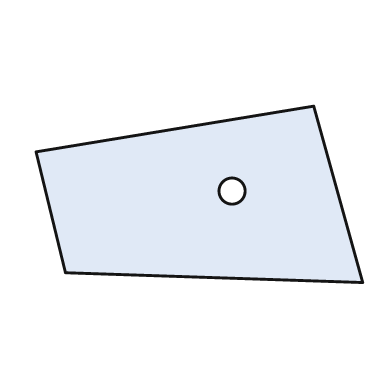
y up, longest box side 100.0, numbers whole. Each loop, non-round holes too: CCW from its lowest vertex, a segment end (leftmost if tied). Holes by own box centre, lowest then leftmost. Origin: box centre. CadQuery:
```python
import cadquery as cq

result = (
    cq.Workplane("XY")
    .moveTo(50.0, -27.0)
    .lineTo(35.0, 27.0)
    .lineTo(-50.0, 13.0)
    .lineTo(-41.0, -24.0)
    .close()
    .moveTo(10.0, 1.0)
    .circle(4.0)
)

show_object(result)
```